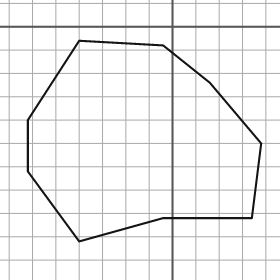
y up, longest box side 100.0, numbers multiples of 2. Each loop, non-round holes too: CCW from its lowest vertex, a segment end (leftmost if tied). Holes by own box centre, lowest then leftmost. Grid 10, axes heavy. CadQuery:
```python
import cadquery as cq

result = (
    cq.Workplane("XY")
    .moveTo(-40.0, -92.0)
    .lineTo(-4.0, -82.0)
    .lineTo(34.0, -82.0)
    .lineTo(38.0, -50.0)
    .lineTo(16.0, -24.0)
    .lineTo(-4.0, -8.0)
    .lineTo(-40.0, -6.0)
    .lineTo(-62.0, -40.0)
    .lineTo(-62.0, -62.0)
    .close()
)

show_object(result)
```